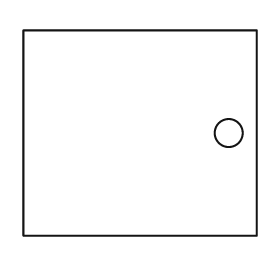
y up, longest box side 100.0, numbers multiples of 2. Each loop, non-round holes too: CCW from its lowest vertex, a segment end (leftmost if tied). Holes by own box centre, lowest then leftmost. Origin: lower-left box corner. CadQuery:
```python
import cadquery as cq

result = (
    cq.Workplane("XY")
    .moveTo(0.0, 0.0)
    .lineTo(100.0, 0.0)
    .lineTo(100.0, 88.0)
    .lineTo(0.0, 88.0)
    .close()
    .moveTo(88.0, 44.0)
    .circle(6.0)
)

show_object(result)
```